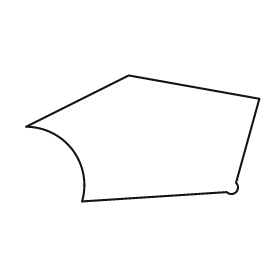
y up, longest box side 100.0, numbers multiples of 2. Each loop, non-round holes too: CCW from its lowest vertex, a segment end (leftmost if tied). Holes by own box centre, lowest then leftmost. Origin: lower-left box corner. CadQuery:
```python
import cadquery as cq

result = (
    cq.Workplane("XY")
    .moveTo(24.0, 0.0)
    .lineTo(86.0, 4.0)
    .threePointArc((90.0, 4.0), (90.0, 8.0))
    .lineTo(100.0, 44.0)
    .lineTo(44.0, 54.0)
    .lineTo(0.0, 32.0)
    .threePointArc((20.0, 22.0), (24.0, 0.0))
    .close()
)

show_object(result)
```